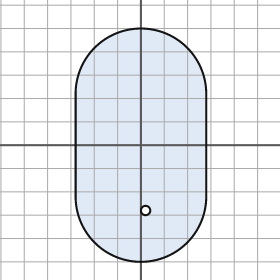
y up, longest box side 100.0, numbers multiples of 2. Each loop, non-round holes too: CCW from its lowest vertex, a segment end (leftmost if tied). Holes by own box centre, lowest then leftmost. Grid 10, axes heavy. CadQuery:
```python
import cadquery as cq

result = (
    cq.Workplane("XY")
    .moveTo(-28.0, -22.0)
    .threePointArc((0.0, -50.0), (28.0, -22.0))
    .lineTo(28.0, 22.0)
    .threePointArc((0.0, 50.0), (-28.0, 22.0))
    .close()
    .moveTo(2.0, -28.0)
    .circle(2.0)
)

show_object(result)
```